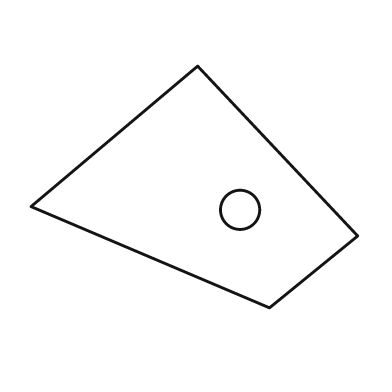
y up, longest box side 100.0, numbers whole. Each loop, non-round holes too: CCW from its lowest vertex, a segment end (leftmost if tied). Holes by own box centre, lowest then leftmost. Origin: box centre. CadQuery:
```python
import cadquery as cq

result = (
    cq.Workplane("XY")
    .moveTo(23.0, -37.0)
    .lineTo(50.0, -15.0)
    .lineTo(1.0, 37.0)
    .lineTo(-50.0, -6.0)
    .close()
    .moveTo(14.0, -7.0)
    .circle(6.0)
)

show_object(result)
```